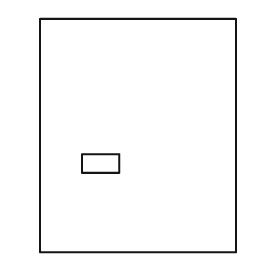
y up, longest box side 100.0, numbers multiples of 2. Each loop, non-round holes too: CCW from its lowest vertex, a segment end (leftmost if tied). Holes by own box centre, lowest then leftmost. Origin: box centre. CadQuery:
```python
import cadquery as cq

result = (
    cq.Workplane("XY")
    .moveTo(-42.0, -50.0)
    .lineTo(42.0, -50.0)
    .lineTo(42.0, 50.0)
    .lineTo(-42.0, 50.0)
    .close()
    .moveTo(-24.0, -16.0)
    .lineTo(-8.0, -16.0)
    .lineTo(-8.0, -8.0)
    .lineTo(-24.0, -8.0)
    .close()
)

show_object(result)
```